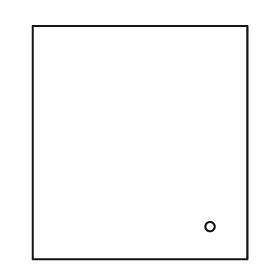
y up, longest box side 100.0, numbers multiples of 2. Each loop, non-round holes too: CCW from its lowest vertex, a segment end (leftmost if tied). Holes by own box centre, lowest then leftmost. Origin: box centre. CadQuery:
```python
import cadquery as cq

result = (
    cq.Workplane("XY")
    .moveTo(-46.0, -50.0)
    .lineTo(46.0, -50.0)
    .lineTo(46.0, 50.0)
    .lineTo(-46.0, 50.0)
    .close()
    .moveTo(30.0, -36.0)
    .circle(2.0)
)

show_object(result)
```